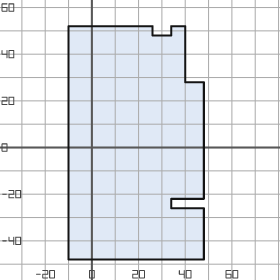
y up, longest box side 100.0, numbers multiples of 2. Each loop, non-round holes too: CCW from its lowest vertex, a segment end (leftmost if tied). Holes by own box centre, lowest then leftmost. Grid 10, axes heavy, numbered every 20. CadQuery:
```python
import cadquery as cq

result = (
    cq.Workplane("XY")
    .moveTo(-10.0, -48.0)
    .lineTo(48.0, -48.0)
    .lineTo(48.0, -26.0)
    .lineTo(34.0, -26.0)
    .lineTo(34.0, -22.0)
    .lineTo(48.0, -22.0)
    .lineTo(48.0, 28.0)
    .lineTo(40.0, 28.0)
    .lineTo(40.0, 52.0)
    .lineTo(34.0, 52.0)
    .lineTo(34.0, 48.0)
    .lineTo(26.0, 48.0)
    .lineTo(26.0, 52.0)
    .lineTo(-10.0, 52.0)
    .close()
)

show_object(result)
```